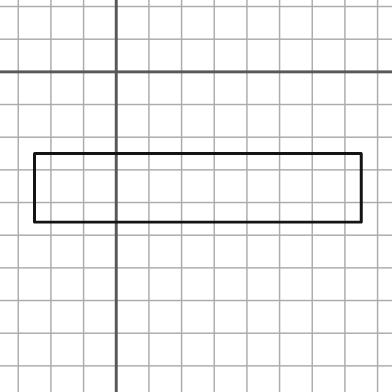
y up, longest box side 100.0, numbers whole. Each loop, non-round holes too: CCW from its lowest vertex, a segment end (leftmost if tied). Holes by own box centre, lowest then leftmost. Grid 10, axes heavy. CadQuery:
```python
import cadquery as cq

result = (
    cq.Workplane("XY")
    .moveTo(-25.0, -46.0)
    .lineTo(75.0, -46.0)
    .lineTo(75.0, -25.0)
    .lineTo(-25.0, -25.0)
    .close()
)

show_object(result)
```